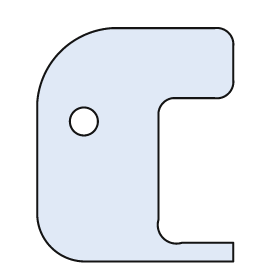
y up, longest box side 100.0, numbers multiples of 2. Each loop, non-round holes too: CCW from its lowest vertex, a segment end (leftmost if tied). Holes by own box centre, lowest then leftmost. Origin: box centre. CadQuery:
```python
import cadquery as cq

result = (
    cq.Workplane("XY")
    .moveTo(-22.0, -50.0)
    .lineTo(42.0, -50.0)
    .lineTo(42.0, -42.0)
    .lineTo(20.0, -42.0)
    .threePointArc((12.0, -40.0), (10.0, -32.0))
    .lineTo(10.0, 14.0)
    .threePointArc((12.0, 18.0), (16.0, 20.0))
    .lineTo(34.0, 20.0)
    .threePointArc((40.0, 22.0), (42.0, 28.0))
    .lineTo(42.0, 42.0)
    .threePointArc((40.0, 48.0), (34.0, 50.0))
    .lineTo(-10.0, 50.0)
    .threePointArc((-32.0, 40.0), (-42.0, 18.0))
    .lineTo(-42.0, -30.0)
    .threePointArc((-36.0, -44.0), (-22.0, -50.0))
    .close()
    .moveTo(-22.0, 10.0)
    .circle(6.0)
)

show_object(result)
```